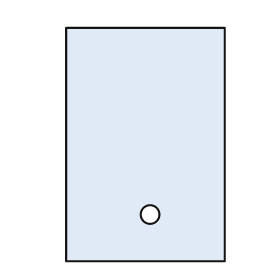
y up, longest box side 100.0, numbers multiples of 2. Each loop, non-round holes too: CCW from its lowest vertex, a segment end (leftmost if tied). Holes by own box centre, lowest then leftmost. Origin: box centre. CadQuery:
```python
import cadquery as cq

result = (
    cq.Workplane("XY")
    .moveTo(-34.0, -50.0)
    .lineTo(34.0, -50.0)
    .lineTo(34.0, 50.0)
    .lineTo(-34.0, 50.0)
    .close()
    .moveTo(2.0, -30.0)
    .circle(4.0)
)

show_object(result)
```